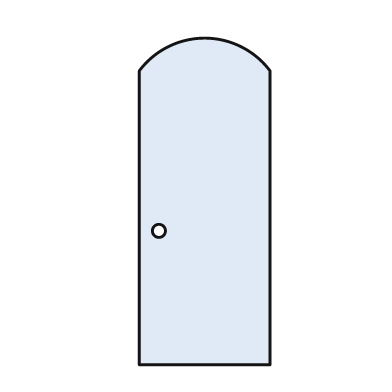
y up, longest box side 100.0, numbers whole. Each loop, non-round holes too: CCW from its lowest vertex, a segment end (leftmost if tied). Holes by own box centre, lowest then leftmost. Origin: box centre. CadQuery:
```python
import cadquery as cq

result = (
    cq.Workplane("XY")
    .moveTo(-20.0, -50.0)
    .lineTo(20.0, -50.0)
    .lineTo(20.0, 40.0)
    .threePointArc((0.0, 50.0), (-20.0, 40.0))
    .close()
    .moveTo(-14.0, -9.0)
    .circle(2.0)
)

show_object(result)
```